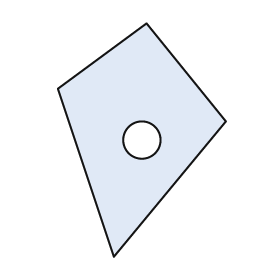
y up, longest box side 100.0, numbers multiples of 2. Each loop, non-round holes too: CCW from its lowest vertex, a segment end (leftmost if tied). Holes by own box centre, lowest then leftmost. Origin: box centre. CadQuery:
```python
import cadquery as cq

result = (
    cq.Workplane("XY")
    .moveTo(-12.0, -50.0)
    .lineTo(36.0, 8.0)
    .lineTo(2.0, 50.0)
    .lineTo(-36.0, 22.0)
    .close()
    .moveTo(0.0, 0.0)
    .circle(8.0)
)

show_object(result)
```